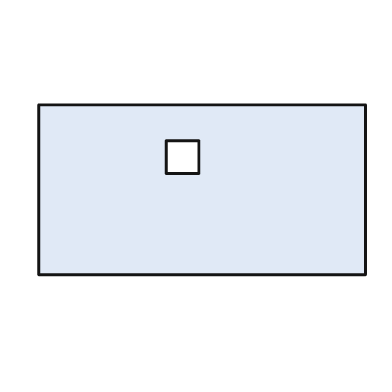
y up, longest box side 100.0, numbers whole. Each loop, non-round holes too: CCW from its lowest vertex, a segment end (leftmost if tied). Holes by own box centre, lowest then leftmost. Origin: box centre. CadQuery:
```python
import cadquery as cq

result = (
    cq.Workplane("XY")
    .moveTo(-50.0, -26.0)
    .lineTo(50.0, -26.0)
    .lineTo(50.0, 26.0)
    .lineTo(-50.0, 26.0)
    .close()
    .moveTo(-11.0, 5.0)
    .lineTo(-1.0, 5.0)
    .lineTo(-1.0, 15.0)
    .lineTo(-11.0, 15.0)
    .close()
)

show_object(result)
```